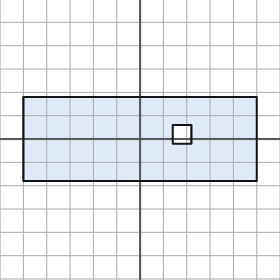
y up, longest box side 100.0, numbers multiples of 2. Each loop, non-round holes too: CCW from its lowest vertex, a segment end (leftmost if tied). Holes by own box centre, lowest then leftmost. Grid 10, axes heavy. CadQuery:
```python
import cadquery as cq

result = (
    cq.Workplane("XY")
    .moveTo(-50.0, -18.0)
    .lineTo(50.0, -18.0)
    .lineTo(50.0, 18.0)
    .lineTo(-50.0, 18.0)
    .close()
    .moveTo(14.0, -2.0)
    .lineTo(22.0, -2.0)
    .lineTo(22.0, 6.0)
    .lineTo(14.0, 6.0)
    .close()
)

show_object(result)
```